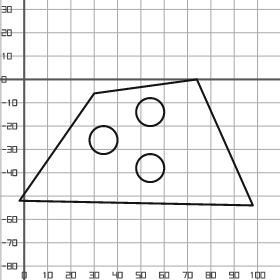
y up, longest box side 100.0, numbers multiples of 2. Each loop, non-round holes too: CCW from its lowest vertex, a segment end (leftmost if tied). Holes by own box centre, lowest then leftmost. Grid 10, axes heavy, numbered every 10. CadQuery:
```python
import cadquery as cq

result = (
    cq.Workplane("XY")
    .moveTo(98.0, -54.0)
    .lineTo(74.0, 0.0)
    .lineTo(30.0, -6.0)
    .lineTo(-2.0, -52.0)
    .close()
    .moveTo(54.0, -38.0)
    .circle(6.0)
    .moveTo(34.0, -26.0)
    .circle(6.0)
    .moveTo(54.0, -14.0)
    .circle(6.0)
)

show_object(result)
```